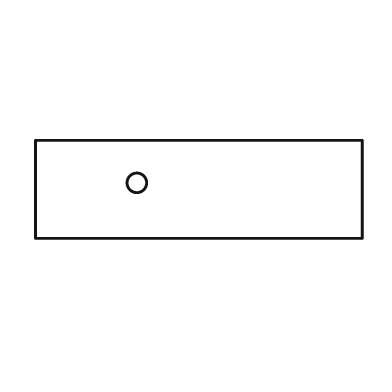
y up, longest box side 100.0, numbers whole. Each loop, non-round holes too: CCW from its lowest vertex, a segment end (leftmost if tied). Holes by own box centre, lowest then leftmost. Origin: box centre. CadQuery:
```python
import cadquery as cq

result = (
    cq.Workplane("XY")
    .moveTo(-50.0, -15.0)
    .lineTo(50.0, -15.0)
    .lineTo(50.0, 15.0)
    .lineTo(-50.0, 15.0)
    .close()
    .moveTo(-19.0, 2.0)
    .circle(3.0)
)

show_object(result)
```